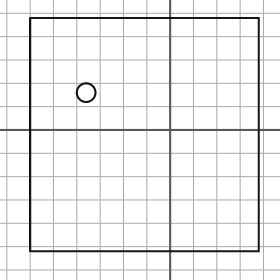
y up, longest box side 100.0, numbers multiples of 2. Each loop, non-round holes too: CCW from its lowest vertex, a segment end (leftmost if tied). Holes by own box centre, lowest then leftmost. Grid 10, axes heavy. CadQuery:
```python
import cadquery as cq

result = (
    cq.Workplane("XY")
    .moveTo(-60.0, -52.0)
    .lineTo(38.0, -52.0)
    .lineTo(38.0, 48.0)
    .lineTo(-60.0, 48.0)
    .close()
    .moveTo(-36.0, 16.0)
    .circle(4.0)
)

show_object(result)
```